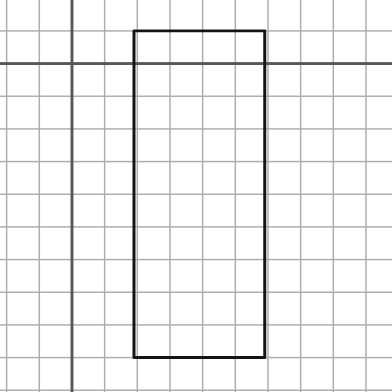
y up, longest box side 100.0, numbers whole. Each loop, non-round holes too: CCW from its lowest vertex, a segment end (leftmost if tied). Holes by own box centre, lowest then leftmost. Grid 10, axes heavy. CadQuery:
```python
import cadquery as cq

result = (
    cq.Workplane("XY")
    .moveTo(19.0, -90.0)
    .lineTo(59.0, -90.0)
    .lineTo(59.0, 10.0)
    .lineTo(19.0, 10.0)
    .close()
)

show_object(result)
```